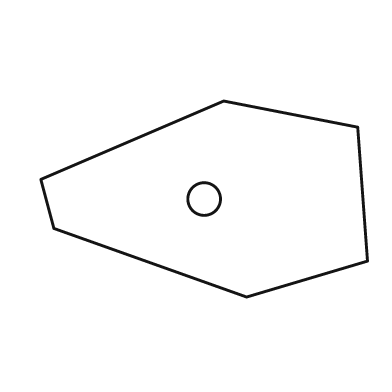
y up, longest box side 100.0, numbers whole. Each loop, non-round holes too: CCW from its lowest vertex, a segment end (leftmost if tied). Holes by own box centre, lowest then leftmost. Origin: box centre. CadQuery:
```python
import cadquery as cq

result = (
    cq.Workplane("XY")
    .moveTo(13.0, -30.0)
    .lineTo(50.0, -19.0)
    .lineTo(47.0, 22.0)
    .lineTo(6.0, 30.0)
    .lineTo(-50.0, 6.0)
    .lineTo(-46.0, -9.0)
    .close()
    .moveTo(0.0, 0.0)
    .circle(5.0)
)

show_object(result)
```